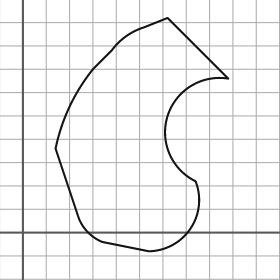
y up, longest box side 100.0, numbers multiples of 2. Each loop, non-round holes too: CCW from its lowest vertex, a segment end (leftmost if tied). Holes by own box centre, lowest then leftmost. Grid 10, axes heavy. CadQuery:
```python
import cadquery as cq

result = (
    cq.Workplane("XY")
    .moveTo(54.0, -8.0)
    .threePointArc((72.0, 2.0), (74.0, 22.0))
    .threePointArc((62.0, 50.0), (88.0, 66.0))
    .lineTo(62.0, 92.0)
    .lineTo(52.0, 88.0)
    .threePointArc((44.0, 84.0), (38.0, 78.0))
    .lineTo(30.0, 70.0)
    .threePointArc((20.0, 54.0), (14.0, 36.0))
    .lineTo(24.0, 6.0)
    .threePointArc((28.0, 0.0), (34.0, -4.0))
    .close()
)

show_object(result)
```